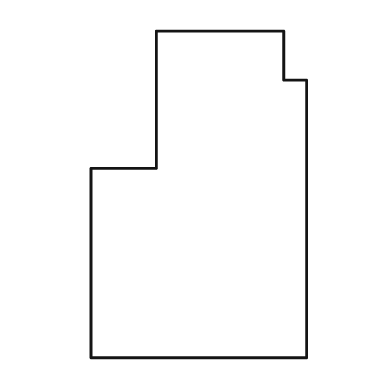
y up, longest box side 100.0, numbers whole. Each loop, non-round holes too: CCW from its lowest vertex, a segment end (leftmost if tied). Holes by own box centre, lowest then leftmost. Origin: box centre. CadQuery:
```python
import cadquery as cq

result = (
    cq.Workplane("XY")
    .moveTo(-33.0, -50.0)
    .lineTo(33.0, -50.0)
    .lineTo(33.0, 35.0)
    .lineTo(26.0, 35.0)
    .lineTo(26.0, 50.0)
    .lineTo(-13.0, 50.0)
    .lineTo(-13.0, 8.0)
    .lineTo(-33.0, 8.0)
    .close()
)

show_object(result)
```